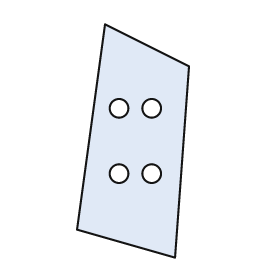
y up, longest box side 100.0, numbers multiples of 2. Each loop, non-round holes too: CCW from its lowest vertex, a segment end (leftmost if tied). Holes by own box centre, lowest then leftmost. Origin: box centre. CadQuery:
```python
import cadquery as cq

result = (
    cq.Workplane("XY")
    .moveTo(18.0, -50.0)
    .lineTo(24.0, 32.0)
    .lineTo(-12.0, 50.0)
    .lineTo(-24.0, -38.0)
    .close()
    .moveTo(-6.0, -14.0)
    .circle(4.0)
    .moveTo(8.0, -14.0)
    .circle(4.0)
    .moveTo(-6.0, 14.0)
    .circle(4.0)
    .moveTo(8.0, 14.0)
    .circle(4.0)
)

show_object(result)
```